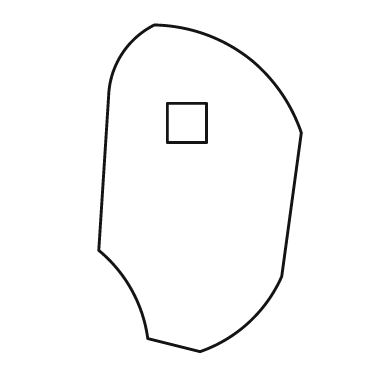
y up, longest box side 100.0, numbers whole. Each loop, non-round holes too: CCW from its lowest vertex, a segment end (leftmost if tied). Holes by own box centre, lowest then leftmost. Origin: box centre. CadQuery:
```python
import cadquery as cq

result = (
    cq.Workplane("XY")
    .moveTo(0.0, -50.0)
    .threePointArc((15.0, -41.0), (25.0, -27.0))
    .lineTo(31.0, 17.0)
    .threePointArc((25.0, 29.0), (16.0, 39.0))
    .threePointArc((2.0, 47.0), (-14.0, 50.0))
    .threePointArc((-24.0, 41.0), (-28.0, 28.0))
    .lineTo(-31.0, -19.0)
    .threePointArc((-21.0, -31.0), (-16.0, -46.0))
    .close()
    .moveTo(-10.0, 14.0)
    .lineTo(2.0, 14.0)
    .lineTo(2.0, 26.0)
    .lineTo(-10.0, 26.0)
    .close()
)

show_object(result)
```